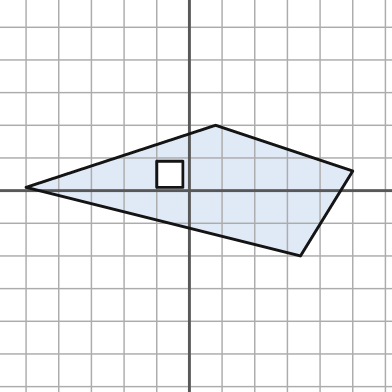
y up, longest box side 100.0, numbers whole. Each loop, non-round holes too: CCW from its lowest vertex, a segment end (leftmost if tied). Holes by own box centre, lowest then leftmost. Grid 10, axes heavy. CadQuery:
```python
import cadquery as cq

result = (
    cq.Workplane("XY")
    .moveTo(34.0, -20.0)
    .lineTo(50.0, 6.0)
    .lineTo(8.0, 20.0)
    .lineTo(-50.0, 1.0)
    .close()
    .moveTo(-10.0, 1.0)
    .lineTo(-2.0, 1.0)
    .lineTo(-2.0, 9.0)
    .lineTo(-10.0, 9.0)
    .close()
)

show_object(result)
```